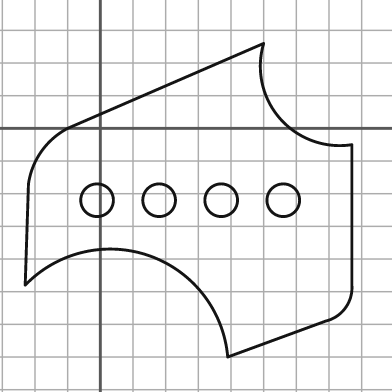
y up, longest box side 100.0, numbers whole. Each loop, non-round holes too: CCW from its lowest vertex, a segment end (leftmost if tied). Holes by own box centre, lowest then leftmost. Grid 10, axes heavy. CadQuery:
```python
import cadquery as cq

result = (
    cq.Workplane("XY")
    .moveTo(39.0, -70.0)
    .lineTo(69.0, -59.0)
    .threePointArc((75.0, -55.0), (77.0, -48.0))
    .lineTo(77.0, -5.0)
    .threePointArc((55.0, 3.0), (50.0, 26.0))
    .lineTo(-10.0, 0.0)
    .threePointArc((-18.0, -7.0), (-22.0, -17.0))
    .lineTo(-23.0, -48.0)
    .threePointArc((15.0, -39.0), (39.0, -70.0))
    .close()
    .moveTo(-1.0, -22.0)
    .circle(5.0)
    .moveTo(18.0, -22.0)
    .circle(5.0)
    .moveTo(37.0, -22.0)
    .circle(5.0)
    .moveTo(56.0, -22.0)
    .circle(5.0)
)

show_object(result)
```